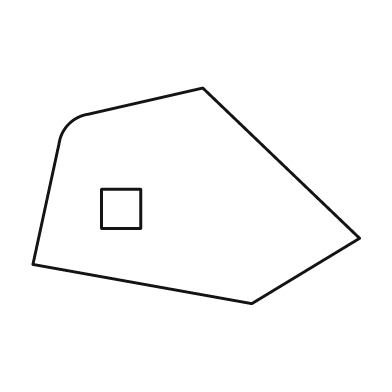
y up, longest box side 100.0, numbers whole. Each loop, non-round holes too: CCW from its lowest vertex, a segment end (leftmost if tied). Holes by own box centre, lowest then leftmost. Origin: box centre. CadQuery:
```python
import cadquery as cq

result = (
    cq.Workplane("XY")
    .moveTo(17.0, -33.0)
    .lineTo(50.0, -13.0)
    .lineTo(2.0, 33.0)
    .lineTo(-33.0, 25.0)
    .threePointArc((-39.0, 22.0), (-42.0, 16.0))
    .lineTo(-50.0, -21.0)
    .close()
    .moveTo(-29.0, -10.0)
    .lineTo(-17.0, -10.0)
    .lineTo(-17.0, 2.0)
    .lineTo(-29.0, 2.0)
    .close()
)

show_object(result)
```